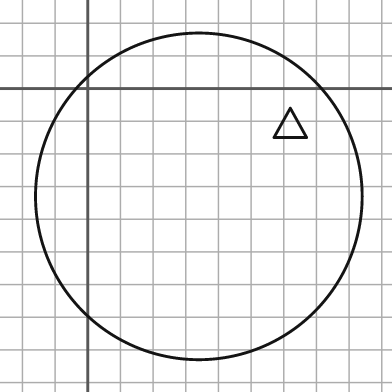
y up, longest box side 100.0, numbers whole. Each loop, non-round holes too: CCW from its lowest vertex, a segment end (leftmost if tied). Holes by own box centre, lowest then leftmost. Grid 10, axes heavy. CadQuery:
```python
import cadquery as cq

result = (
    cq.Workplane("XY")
    .moveTo(34.0, -33.0)
    .circle(50.0)
    .moveTo(57.0, -15.0)
    .lineTo(67.0, -15.0)
    .lineTo(62.0, -6.0)
    .close()
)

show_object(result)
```